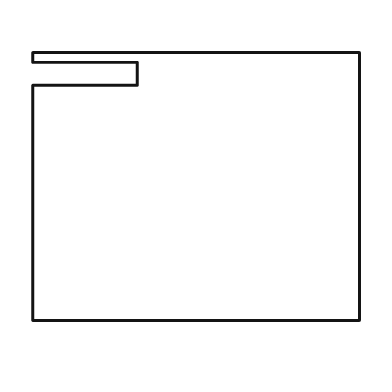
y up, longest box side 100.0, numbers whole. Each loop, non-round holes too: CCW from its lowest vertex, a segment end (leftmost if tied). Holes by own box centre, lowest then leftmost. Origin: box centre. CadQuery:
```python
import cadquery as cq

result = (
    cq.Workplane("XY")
    .moveTo(-50.0, -41.0)
    .lineTo(50.0, -41.0)
    .lineTo(50.0, 41.0)
    .lineTo(-50.0, 41.0)
    .lineTo(-50.0, 38.0)
    .lineTo(-18.0, 38.0)
    .lineTo(-18.0, 31.0)
    .lineTo(-50.0, 31.0)
    .close()
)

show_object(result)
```